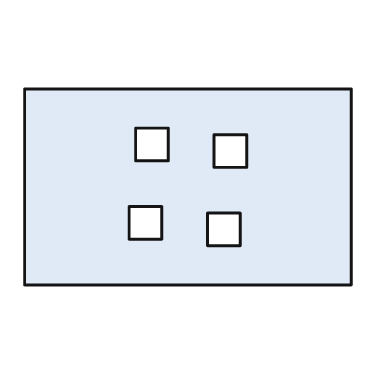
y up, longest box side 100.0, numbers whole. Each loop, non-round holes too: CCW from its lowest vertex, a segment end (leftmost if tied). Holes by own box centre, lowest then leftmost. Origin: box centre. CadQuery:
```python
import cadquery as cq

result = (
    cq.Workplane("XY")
    .moveTo(-50.0, -30.0)
    .lineTo(50.0, -30.0)
    .lineTo(50.0, 30.0)
    .lineTo(-50.0, 30.0)
    .close()
    .moveTo(6.0, -18.0)
    .lineTo(16.0, -18.0)
    .lineTo(16.0, -8.0)
    .lineTo(6.0, -8.0)
    .close()
    .moveTo(-18.0, -16.0)
    .lineTo(-8.0, -16.0)
    .lineTo(-8.0, -6.0)
    .lineTo(-18.0, -6.0)
    .close()
    .moveTo(8.0, 6.0)
    .lineTo(18.0, 6.0)
    .lineTo(18.0, 16.0)
    .lineTo(8.0, 16.0)
    .close()
    .moveTo(-16.0, 8.0)
    .lineTo(-6.0, 8.0)
    .lineTo(-6.0, 18.0)
    .lineTo(-16.0, 18.0)
    .close()
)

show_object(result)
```